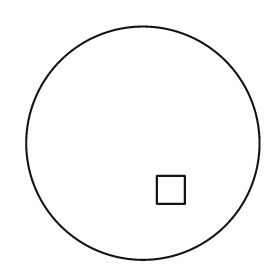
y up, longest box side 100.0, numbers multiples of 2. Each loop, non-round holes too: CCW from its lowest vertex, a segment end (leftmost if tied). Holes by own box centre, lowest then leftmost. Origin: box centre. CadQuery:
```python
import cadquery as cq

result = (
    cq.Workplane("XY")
    .moveTo(0.0, 0.0)
    .circle(50.0)
    .moveTo(6.0, -26.0)
    .lineTo(18.0, -26.0)
    .lineTo(18.0, -14.0)
    .lineTo(6.0, -14.0)
    .close()
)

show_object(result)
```